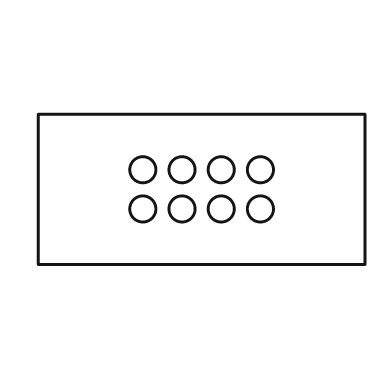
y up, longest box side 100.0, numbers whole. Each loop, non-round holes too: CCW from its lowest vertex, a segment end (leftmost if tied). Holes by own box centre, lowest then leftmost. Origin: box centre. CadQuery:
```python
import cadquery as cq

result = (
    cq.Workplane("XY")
    .moveTo(-50.0, -23.0)
    .lineTo(50.0, -23.0)
    .lineTo(50.0, 23.0)
    .lineTo(-50.0, 23.0)
    .close()
    .moveTo(-18.0, -6.0)
    .circle(4.0)
    .moveTo(-6.0, -6.0)
    .circle(4.0)
    .moveTo(6.0, -6.0)
    .circle(4.0)
    .moveTo(18.0, -6.0)
    .circle(4.0)
    .moveTo(-18.0, 6.0)
    .circle(4.0)
    .moveTo(-6.0, 6.0)
    .circle(4.0)
    .moveTo(6.0, 6.0)
    .circle(4.0)
    .moveTo(18.0, 6.0)
    .circle(4.0)
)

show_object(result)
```